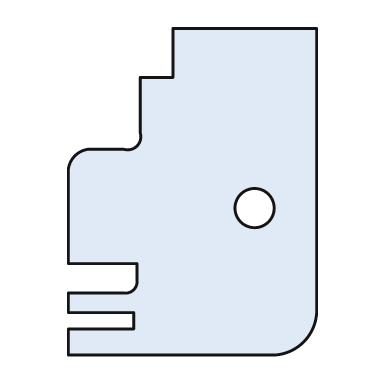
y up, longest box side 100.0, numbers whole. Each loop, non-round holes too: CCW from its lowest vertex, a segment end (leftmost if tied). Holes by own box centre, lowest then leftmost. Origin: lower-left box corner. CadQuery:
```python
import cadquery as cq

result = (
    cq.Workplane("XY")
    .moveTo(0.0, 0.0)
    .lineTo(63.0, 0.0)
    .threePointArc((72.0, 4.0), (76.0, 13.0))
    .lineTo(76.0, 100.0)
    .lineTo(32.0, 100.0)
    .lineTo(32.0, 85.0)
    .lineTo(22.0, 85.0)
    .lineTo(22.0, 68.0)
    .threePointArc((21.0, 64.0), (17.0, 63.0))
    .lineTo(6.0, 63.0)
    .threePointArc((2.0, 61.0), (0.0, 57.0))
    .lineTo(0.0, 28.0)
    .lineTo(21.0, 28.0)
    .lineTo(21.0, 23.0)
    .threePointArc((20.0, 20.0), (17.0, 19.0))
    .lineTo(0.0, 19.0)
    .lineTo(0.0, 13.0)
    .lineTo(20.0, 13.0)
    .lineTo(20.0, 8.0)
    .lineTo(0.0, 8.0)
    .close()
    .moveTo(57.0, 45.0)
    .circle(6.0)
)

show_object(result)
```